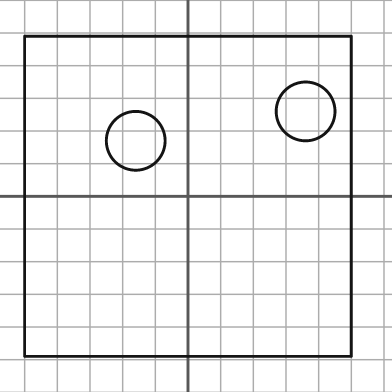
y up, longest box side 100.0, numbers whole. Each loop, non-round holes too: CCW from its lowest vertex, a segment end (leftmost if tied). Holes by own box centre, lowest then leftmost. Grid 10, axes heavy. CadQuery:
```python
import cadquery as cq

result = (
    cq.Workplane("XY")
    .moveTo(-50.0, -49.0)
    .lineTo(50.0, -49.0)
    .lineTo(50.0, 49.0)
    .lineTo(-50.0, 49.0)
    .close()
    .moveTo(-16.0, 17.0)
    .circle(9.0)
    .moveTo(36.0, 26.0)
    .circle(9.0)
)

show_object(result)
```